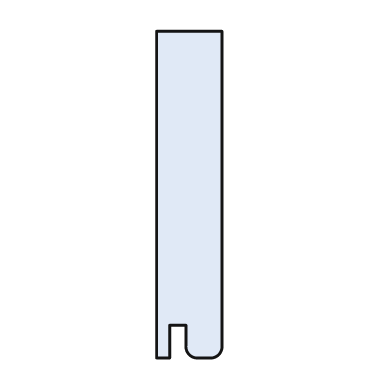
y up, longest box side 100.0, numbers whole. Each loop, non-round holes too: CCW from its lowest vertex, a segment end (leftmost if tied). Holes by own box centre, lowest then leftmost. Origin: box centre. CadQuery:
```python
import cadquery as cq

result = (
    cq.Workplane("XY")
    .moveTo(-10.0, -50.0)
    .lineTo(-6.0, -50.0)
    .lineTo(-6.0, -40.0)
    .lineTo(-1.0, -40.0)
    .lineTo(-1.0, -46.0)
    .threePointArc((0.0, -49.0), (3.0, -50.0))
    .lineTo(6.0, -50.0)
    .threePointArc((9.0, -49.0), (10.0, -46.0))
    .lineTo(10.0, 50.0)
    .lineTo(-10.0, 50.0)
    .close()
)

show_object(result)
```